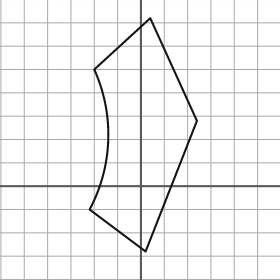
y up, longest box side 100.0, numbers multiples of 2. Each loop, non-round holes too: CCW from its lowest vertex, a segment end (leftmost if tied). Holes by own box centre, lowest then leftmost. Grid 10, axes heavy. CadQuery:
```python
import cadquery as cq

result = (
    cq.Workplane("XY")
    .moveTo(2.0, -28.0)
    .lineTo(24.0, 28.0)
    .lineTo(4.0, 72.0)
    .lineTo(-20.0, 50.0)
    .threePointArc((-14.0, 20.0), (-22.0, -10.0))
    .close()
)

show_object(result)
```